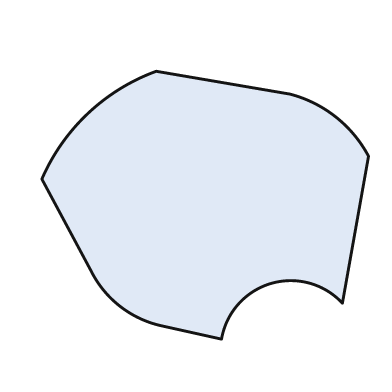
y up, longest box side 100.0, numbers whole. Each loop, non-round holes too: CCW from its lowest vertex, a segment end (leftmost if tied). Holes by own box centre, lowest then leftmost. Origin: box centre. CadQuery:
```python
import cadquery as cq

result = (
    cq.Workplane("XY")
    .moveTo(5.0, -41.0)
    .threePointArc((20.0, -24.0), (42.0, -30.0))
    .lineTo(50.0, 15.0)
    .threePointArc((40.0, 27.0), (26.0, 34.0))
    .lineTo(-15.0, 41.0)
    .threePointArc((-36.0, 28.0), (-50.0, 8.0))
    .lineTo(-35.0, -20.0)
    .threePointArc((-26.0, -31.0), (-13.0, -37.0))
    .close()
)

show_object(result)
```